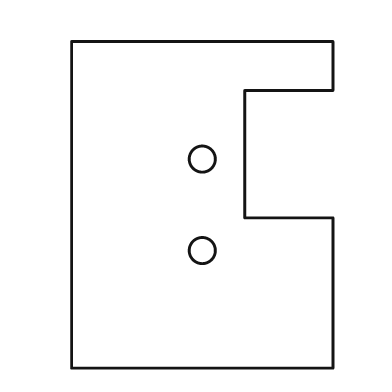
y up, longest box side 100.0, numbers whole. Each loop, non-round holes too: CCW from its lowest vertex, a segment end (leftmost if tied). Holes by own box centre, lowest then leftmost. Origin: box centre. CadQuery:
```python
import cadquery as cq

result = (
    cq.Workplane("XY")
    .moveTo(-40.0, -50.0)
    .lineTo(40.0, -50.0)
    .lineTo(40.0, -4.0)
    .lineTo(13.0, -4.0)
    .lineTo(13.0, 35.0)
    .lineTo(40.0, 35.0)
    .lineTo(40.0, 50.0)
    .lineTo(-40.0, 50.0)
    .close()
    .moveTo(0.0, -14.0)
    .circle(4.0)
    .moveTo(0.0, 14.0)
    .circle(4.0)
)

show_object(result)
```